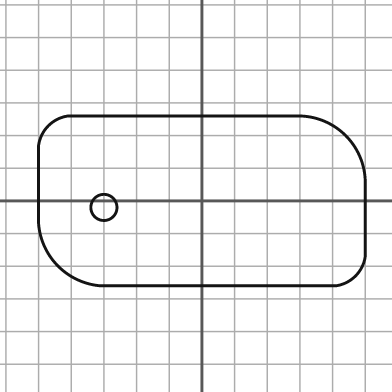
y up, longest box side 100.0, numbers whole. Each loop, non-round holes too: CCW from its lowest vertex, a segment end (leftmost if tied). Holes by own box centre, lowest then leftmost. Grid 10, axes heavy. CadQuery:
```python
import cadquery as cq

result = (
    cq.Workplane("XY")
    .moveTo(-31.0, -26.0)
    .lineTo(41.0, -26.0)
    .threePointArc((47.0, -23.0), (50.0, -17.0))
    .lineTo(50.0, 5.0)
    .threePointArc((44.0, 20.0), (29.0, 26.0))
    .lineTo(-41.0, 26.0)
    .threePointArc((-47.0, 23.0), (-50.0, 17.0))
    .lineTo(-50.0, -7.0)
    .threePointArc((-44.0, -20.0), (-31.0, -26.0))
    .close()
    .moveTo(-30.0, -2.0)
    .circle(4.0)
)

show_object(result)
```